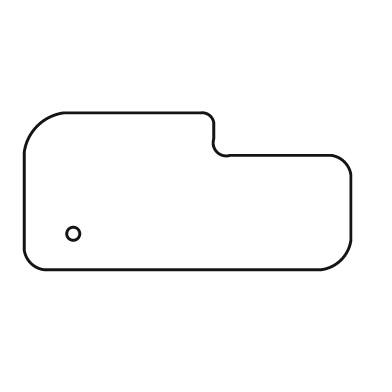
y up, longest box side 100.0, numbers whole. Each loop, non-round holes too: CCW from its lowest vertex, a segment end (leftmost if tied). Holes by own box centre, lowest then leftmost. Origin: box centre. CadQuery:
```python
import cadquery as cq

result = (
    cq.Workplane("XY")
    .moveTo(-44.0, -24.0)
    .lineTo(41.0, -24.0)
    .threePointArc((47.0, -21.0), (50.0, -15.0))
    .lineTo(50.0, 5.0)
    .threePointArc((48.0, 9.0), (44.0, 11.0))
    .lineTo(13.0, 11.0)
    .threePointArc((9.0, 12.0), (8.0, 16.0))
    .lineTo(8.0, 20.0)
    .threePointArc((7.0, 23.0), (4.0, 24.0))
    .lineTo(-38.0, 24.0)
    .threePointArc((-46.0, 20.0), (-50.0, 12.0))
    .lineTo(-50.0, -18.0)
    .threePointArc((-48.0, -22.0), (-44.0, -24.0))
    .close()
    .moveTo(-35.0, -13.0)
    .circle(2.0)
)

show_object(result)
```